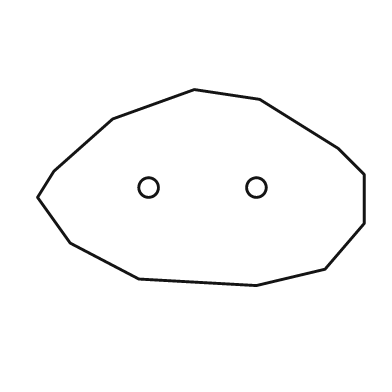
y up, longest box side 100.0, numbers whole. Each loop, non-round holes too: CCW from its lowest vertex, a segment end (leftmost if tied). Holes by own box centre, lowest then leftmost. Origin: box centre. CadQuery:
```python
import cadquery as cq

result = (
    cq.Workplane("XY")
    .moveTo(17.0, -30.0)
    .lineTo(38.0, -25.0)
    .lineTo(50.0, -11.0)
    .lineTo(50.0, 4.0)
    .lineTo(42.0, 12.0)
    .lineTo(18.0, 27.0)
    .lineTo(-2.0, 30.0)
    .lineTo(-27.0, 21.0)
    .lineTo(-45.0, 5.0)
    .lineTo(-50.0, -3.0)
    .lineTo(-40.0, -17.0)
    .lineTo(-19.0, -28.0)
    .close()
    .moveTo(-16.0, 0.0)
    .circle(3.0)
    .moveTo(17.0, 0.0)
    .circle(3.0)
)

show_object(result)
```